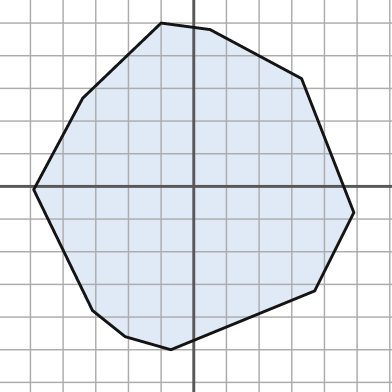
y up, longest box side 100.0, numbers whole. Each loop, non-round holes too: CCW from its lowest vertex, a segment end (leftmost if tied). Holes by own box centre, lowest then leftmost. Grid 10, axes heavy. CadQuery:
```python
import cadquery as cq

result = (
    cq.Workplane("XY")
    .moveTo(-7.0, -50.0)
    .lineTo(37.0, -32.0)
    .lineTo(49.0, -8.0)
    .lineTo(33.0, 33.0)
    .lineTo(5.0, 48.0)
    .lineTo(-10.0, 50.0)
    .lineTo(-34.0, 27.0)
    .lineTo(-49.0, -1.0)
    .lineTo(-31.0, -38.0)
    .lineTo(-21.0, -46.0)
    .close()
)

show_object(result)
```